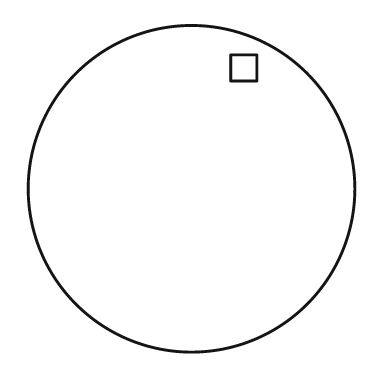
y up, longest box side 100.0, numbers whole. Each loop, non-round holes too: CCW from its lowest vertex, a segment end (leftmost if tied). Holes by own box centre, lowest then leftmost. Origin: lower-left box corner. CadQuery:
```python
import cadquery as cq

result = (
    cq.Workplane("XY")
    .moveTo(50.0, 50.0)
    .circle(50.0)
    .moveTo(62.0, 83.0)
    .lineTo(70.0, 83.0)
    .lineTo(70.0, 91.0)
    .lineTo(62.0, 91.0)
    .close()
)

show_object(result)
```